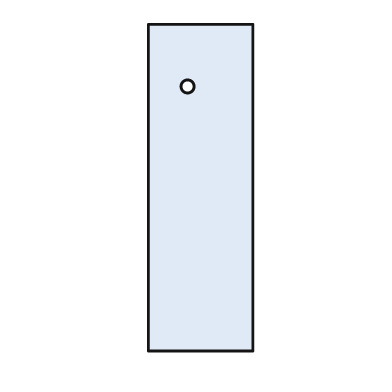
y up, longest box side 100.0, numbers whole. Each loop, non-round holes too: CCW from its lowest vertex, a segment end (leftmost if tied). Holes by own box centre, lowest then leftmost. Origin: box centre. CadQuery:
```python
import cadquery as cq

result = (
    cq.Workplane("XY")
    .moveTo(-16.0, -50.0)
    .lineTo(16.0, -50.0)
    .lineTo(16.0, 50.0)
    .lineTo(-16.0, 50.0)
    .close()
    .moveTo(-4.0, 31.0)
    .circle(2.0)
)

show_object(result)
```